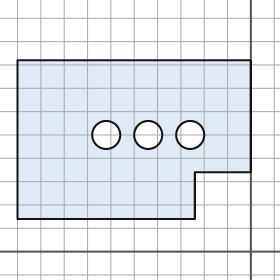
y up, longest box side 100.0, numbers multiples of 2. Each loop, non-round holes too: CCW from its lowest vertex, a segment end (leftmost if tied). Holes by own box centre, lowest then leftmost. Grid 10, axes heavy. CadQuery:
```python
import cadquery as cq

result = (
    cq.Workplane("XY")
    .moveTo(-100.0, 14.0)
    .lineTo(-24.0, 14.0)
    .lineTo(-24.0, 34.0)
    .lineTo(0.0, 34.0)
    .lineTo(0.0, 82.0)
    .lineTo(-100.0, 82.0)
    .close()
    .moveTo(-62.0, 50.0)
    .circle(6.0)
    .moveTo(-44.0, 50.0)
    .circle(6.0)
    .moveTo(-26.0, 50.0)
    .circle(6.0)
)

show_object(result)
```